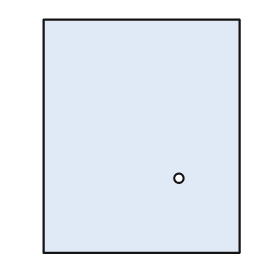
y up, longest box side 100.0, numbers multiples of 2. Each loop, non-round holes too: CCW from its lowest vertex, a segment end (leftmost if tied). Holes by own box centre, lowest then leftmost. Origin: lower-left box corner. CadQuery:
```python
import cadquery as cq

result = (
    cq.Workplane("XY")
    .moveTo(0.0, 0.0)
    .lineTo(84.0, 0.0)
    .lineTo(84.0, 100.0)
    .lineTo(0.0, 100.0)
    .close()
    .moveTo(58.0, 32.0)
    .circle(2.0)
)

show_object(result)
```